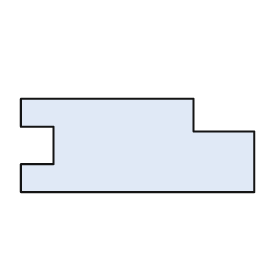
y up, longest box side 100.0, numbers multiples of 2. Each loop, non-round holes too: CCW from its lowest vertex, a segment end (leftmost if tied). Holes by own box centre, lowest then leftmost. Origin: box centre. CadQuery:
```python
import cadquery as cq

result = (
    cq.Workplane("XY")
    .moveTo(-50.0, -20.0)
    .lineTo(50.0, -20.0)
    .lineTo(50.0, 6.0)
    .lineTo(24.0, 6.0)
    .lineTo(24.0, 20.0)
    .lineTo(-50.0, 20.0)
    .lineTo(-50.0, 8.0)
    .lineTo(-36.0, 8.0)
    .lineTo(-36.0, -8.0)
    .lineTo(-50.0, -8.0)
    .close()
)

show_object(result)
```